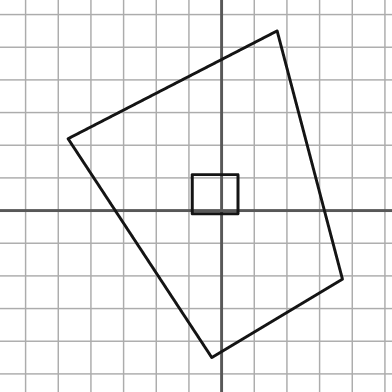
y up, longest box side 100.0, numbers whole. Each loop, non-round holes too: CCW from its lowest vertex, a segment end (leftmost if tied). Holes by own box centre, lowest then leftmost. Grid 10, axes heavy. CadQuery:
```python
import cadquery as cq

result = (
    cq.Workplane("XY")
    .moveTo(-3.0, -45.0)
    .lineTo(37.0, -21.0)
    .lineTo(17.0, 55.0)
    .lineTo(-47.0, 22.0)
    .close()
    .moveTo(-9.0, -1.0)
    .lineTo(5.0, -1.0)
    .lineTo(5.0, 11.0)
    .lineTo(-9.0, 11.0)
    .close()
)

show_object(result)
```